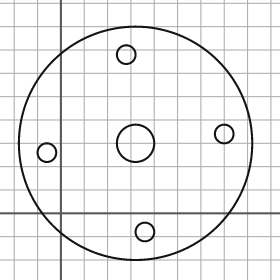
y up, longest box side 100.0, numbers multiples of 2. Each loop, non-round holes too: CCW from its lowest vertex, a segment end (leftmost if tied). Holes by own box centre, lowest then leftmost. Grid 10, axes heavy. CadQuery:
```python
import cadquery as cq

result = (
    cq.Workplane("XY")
    .moveTo(32.0, 30.0)
    .circle(50.0)
    .moveTo(36.0, -8.0)
    .circle(4.0)
    .moveTo(-6.0, 26.0)
    .circle(4.0)
    .moveTo(32.0, 30.0)
    .circle(8.0)
    .moveTo(70.0, 34.0)
    .circle(4.0)
    .moveTo(28.0, 68.0)
    .circle(4.0)
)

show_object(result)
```